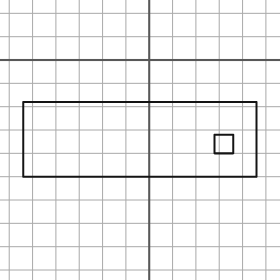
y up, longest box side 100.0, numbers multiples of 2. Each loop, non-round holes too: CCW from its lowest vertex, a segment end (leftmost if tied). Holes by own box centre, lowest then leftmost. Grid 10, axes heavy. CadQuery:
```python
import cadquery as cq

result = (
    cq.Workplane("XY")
    .moveTo(-54.0, -50.0)
    .lineTo(46.0, -50.0)
    .lineTo(46.0, -18.0)
    .lineTo(-54.0, -18.0)
    .close()
    .moveTo(28.0, -40.0)
    .lineTo(36.0, -40.0)
    .lineTo(36.0, -32.0)
    .lineTo(28.0, -32.0)
    .close()
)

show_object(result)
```